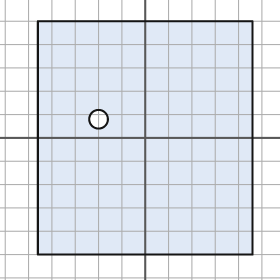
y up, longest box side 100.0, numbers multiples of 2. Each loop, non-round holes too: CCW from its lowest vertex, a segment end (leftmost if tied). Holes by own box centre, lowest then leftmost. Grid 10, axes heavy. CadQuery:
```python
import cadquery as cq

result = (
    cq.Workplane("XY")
    .moveTo(-46.0, -50.0)
    .lineTo(46.0, -50.0)
    .lineTo(46.0, 50.0)
    .lineTo(-46.0, 50.0)
    .close()
    .moveTo(-20.0, 8.0)
    .circle(4.0)
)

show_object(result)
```